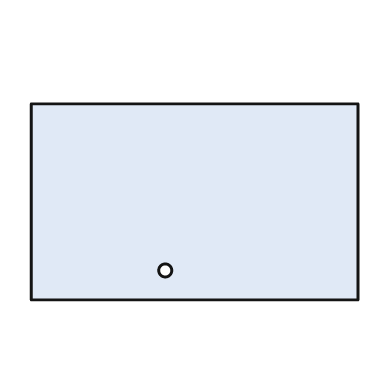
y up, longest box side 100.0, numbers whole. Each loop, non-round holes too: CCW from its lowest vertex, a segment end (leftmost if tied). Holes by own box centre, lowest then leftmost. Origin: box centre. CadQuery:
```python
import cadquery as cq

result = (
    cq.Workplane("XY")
    .moveTo(-50.0, -30.0)
    .lineTo(50.0, -30.0)
    .lineTo(50.0, 30.0)
    .lineTo(-50.0, 30.0)
    .close()
    .moveTo(-9.0, -21.0)
    .circle(2.0)
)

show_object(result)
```